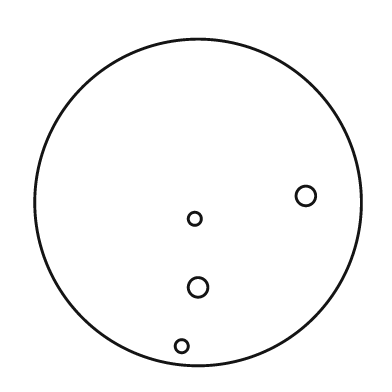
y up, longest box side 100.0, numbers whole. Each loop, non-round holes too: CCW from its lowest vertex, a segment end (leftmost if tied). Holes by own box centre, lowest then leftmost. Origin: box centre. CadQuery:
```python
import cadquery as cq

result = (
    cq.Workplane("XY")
    .moveTo(0.0, 0.0)
    .circle(50.0)
    .moveTo(-5.0, -44.0)
    .circle(2.0)
    .moveTo(0.0, -26.0)
    .circle(3.0)
    .moveTo(-1.0, -5.0)
    .circle(2.0)
    .moveTo(33.0, 2.0)
    .circle(3.0)
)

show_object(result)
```